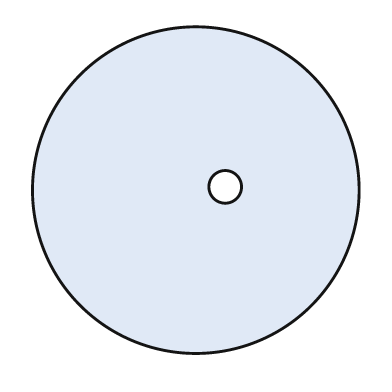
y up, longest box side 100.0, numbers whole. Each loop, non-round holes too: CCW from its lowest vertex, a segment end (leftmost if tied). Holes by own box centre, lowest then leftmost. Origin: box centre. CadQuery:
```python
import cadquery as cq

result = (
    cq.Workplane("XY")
    .moveTo(0.0, 0.0)
    .circle(50.0)
    .moveTo(9.0, 1.0)
    .circle(5.0)
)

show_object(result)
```